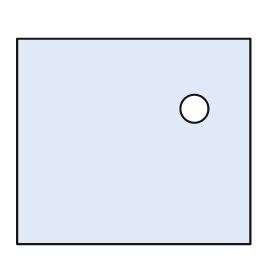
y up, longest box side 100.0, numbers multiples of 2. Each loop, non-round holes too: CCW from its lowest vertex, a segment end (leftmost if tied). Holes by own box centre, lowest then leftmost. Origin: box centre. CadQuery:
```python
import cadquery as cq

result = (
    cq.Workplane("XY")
    .moveTo(-50.0, -44.0)
    .lineTo(50.0, -44.0)
    .lineTo(50.0, 44.0)
    .lineTo(-50.0, 44.0)
    .close()
    .moveTo(26.0, 14.0)
    .circle(6.0)
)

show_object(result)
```